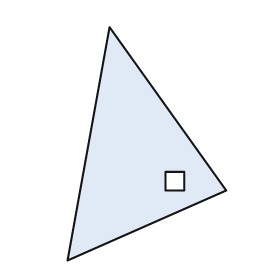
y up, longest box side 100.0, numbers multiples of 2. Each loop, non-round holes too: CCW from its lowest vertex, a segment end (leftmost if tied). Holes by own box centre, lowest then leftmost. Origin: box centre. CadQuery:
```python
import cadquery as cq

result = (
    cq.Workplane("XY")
    .moveTo(-34.0, -50.0)
    .lineTo(34.0, -20.0)
    .lineTo(-16.0, 50.0)
    .close()
    .moveTo(8.0, -20.0)
    .lineTo(16.0, -20.0)
    .lineTo(16.0, -12.0)
    .lineTo(8.0, -12.0)
    .close()
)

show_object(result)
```